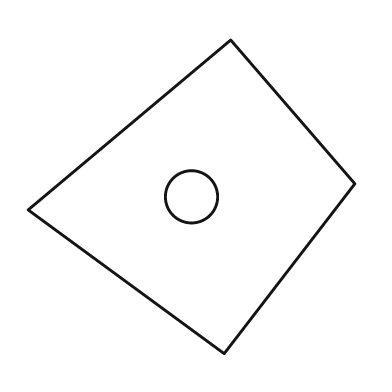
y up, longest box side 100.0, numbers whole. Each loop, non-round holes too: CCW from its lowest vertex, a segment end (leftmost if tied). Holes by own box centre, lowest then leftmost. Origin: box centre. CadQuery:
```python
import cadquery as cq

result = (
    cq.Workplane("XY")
    .moveTo(10.0, -48.0)
    .lineTo(50.0, 4.0)
    .lineTo(12.0, 48.0)
    .lineTo(-50.0, -4.0)
    .close()
    .moveTo(0.0, 0.0)
    .circle(8.0)
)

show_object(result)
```